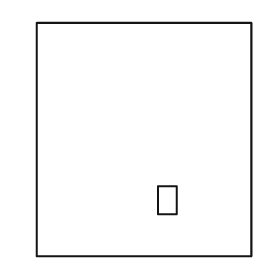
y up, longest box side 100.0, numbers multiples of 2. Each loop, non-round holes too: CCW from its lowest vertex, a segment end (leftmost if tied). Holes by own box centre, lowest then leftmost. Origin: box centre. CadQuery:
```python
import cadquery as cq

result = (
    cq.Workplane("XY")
    .moveTo(-46.0, -50.0)
    .lineTo(46.0, -50.0)
    .lineTo(46.0, 50.0)
    .lineTo(-46.0, 50.0)
    .close()
    .moveTo(6.0, -32.0)
    .lineTo(14.0, -32.0)
    .lineTo(14.0, -20.0)
    .lineTo(6.0, -20.0)
    .close()
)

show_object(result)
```